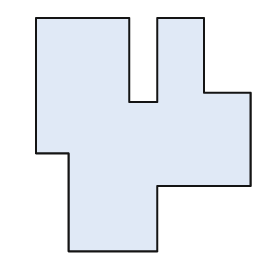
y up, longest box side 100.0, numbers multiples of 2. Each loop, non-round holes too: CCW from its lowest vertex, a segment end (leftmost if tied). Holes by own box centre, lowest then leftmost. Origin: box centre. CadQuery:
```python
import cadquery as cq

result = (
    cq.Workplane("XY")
    .moveTo(-32.0, -50.0)
    .lineTo(6.0, -50.0)
    .lineTo(6.0, -22.0)
    .lineTo(46.0, -22.0)
    .lineTo(46.0, 18.0)
    .lineTo(26.0, 18.0)
    .lineTo(26.0, 50.0)
    .lineTo(6.0, 50.0)
    .lineTo(6.0, 14.0)
    .lineTo(-6.0, 14.0)
    .lineTo(-6.0, 50.0)
    .lineTo(-46.0, 50.0)
    .lineTo(-46.0, -8.0)
    .lineTo(-32.0, -8.0)
    .close()
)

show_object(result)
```